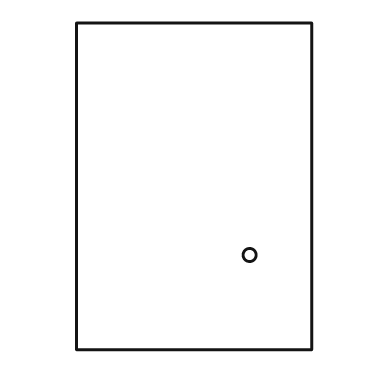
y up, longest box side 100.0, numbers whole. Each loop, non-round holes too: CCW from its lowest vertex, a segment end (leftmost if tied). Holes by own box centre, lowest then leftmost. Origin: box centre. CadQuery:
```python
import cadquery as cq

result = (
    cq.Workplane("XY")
    .moveTo(-36.0, -50.0)
    .lineTo(36.0, -50.0)
    .lineTo(36.0, 50.0)
    .lineTo(-36.0, 50.0)
    .close()
    .moveTo(17.0, -21.0)
    .circle(2.0)
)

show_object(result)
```